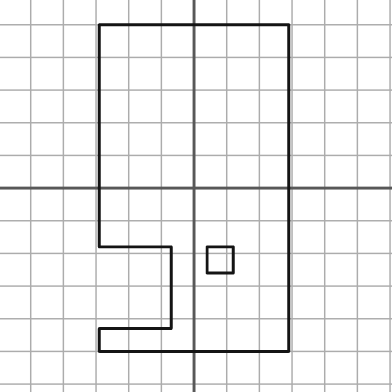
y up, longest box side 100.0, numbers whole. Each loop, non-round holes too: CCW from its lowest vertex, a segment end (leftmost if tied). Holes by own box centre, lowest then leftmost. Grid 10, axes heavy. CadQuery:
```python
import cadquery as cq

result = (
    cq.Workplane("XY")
    .moveTo(-29.0, -50.0)
    .lineTo(29.0, -50.0)
    .lineTo(29.0, 50.0)
    .lineTo(-29.0, 50.0)
    .lineTo(-29.0, -18.0)
    .lineTo(-7.0, -18.0)
    .lineTo(-7.0, -43.0)
    .lineTo(-29.0, -43.0)
    .close()
    .moveTo(4.0, -26.0)
    .lineTo(12.0, -26.0)
    .lineTo(12.0, -18.0)
    .lineTo(4.0, -18.0)
    .close()
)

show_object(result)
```